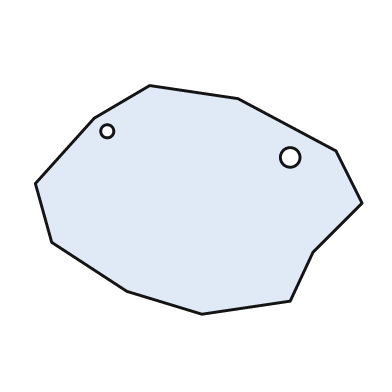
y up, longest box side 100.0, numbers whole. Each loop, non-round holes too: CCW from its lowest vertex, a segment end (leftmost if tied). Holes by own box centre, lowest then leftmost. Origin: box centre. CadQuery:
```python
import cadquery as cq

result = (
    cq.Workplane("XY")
    .moveTo(1.0, -35.0)
    .lineTo(28.0, -31.0)
    .lineTo(35.0, -16.0)
    .lineTo(50.0, -1.0)
    .lineTo(42.0, 15.0)
    .lineTo(12.0, 31.0)
    .lineTo(-15.0, 35.0)
    .lineTo(-32.0, 25.0)
    .lineTo(-50.0, 5.0)
    .lineTo(-45.0, -13.0)
    .lineTo(-22.0, -28.0)
    .close()
    .moveTo(28.0, 13.0)
    .circle(3.0)
    .moveTo(-28.0, 21.0)
    .circle(2.0)
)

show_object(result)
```